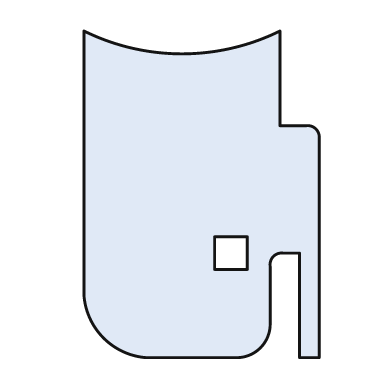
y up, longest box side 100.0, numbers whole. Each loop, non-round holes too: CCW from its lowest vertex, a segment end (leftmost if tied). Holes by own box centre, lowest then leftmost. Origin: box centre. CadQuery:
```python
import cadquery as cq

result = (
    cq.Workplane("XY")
    .moveTo(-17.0, -50.0)
    .lineTo(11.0, -50.0)
    .threePointArc((18.0, -47.0), (21.0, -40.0))
    .lineTo(21.0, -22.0)
    .threePointArc((22.0, -19.0), (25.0, -18.0))
    .lineTo(30.0, -18.0)
    .lineTo(30.0, -50.0)
    .lineTo(36.0, -50.0)
    .lineTo(36.0, 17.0)
    .threePointArc((35.0, 20.0), (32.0, 21.0))
    .lineTo(24.0, 21.0)
    .lineTo(24.0, 50.0)
    .threePointArc((-6.0, 43.0), (-36.0, 50.0))
    .lineTo(-36.0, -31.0)
    .threePointArc((-30.0, -44.0), (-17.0, -50.0))
    .close()
    .moveTo(4.0, -23.0)
    .lineTo(14.0, -23.0)
    .lineTo(14.0, -13.0)
    .lineTo(4.0, -13.0)
    .close()
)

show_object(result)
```